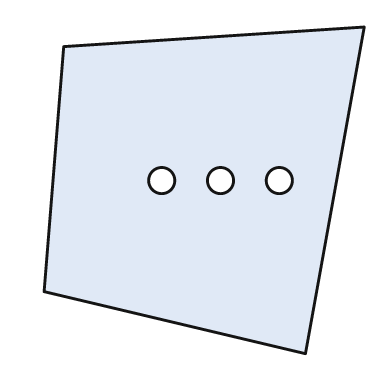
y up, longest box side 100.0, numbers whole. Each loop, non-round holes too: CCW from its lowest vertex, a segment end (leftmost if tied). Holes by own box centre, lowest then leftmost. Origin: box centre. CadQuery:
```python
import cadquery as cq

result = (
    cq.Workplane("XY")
    .moveTo(31.0, -50.0)
    .lineTo(49.0, 50.0)
    .lineTo(-43.0, 44.0)
    .lineTo(-49.0, -31.0)
    .close()
    .moveTo(-13.0, 3.0)
    .circle(4.0)
    .moveTo(5.0, 3.0)
    .circle(4.0)
    .moveTo(23.0, 3.0)
    .circle(4.0)
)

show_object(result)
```